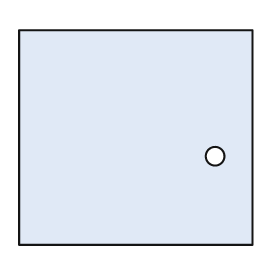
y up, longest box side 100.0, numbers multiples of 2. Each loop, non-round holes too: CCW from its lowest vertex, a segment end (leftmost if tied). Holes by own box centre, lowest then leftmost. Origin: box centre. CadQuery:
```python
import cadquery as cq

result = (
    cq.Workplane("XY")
    .moveTo(-50.0, -46.0)
    .lineTo(50.0, -46.0)
    .lineTo(50.0, 46.0)
    .lineTo(-50.0, 46.0)
    .close()
    .moveTo(34.0, -8.0)
    .circle(4.0)
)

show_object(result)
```